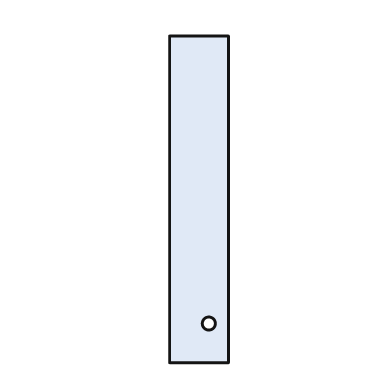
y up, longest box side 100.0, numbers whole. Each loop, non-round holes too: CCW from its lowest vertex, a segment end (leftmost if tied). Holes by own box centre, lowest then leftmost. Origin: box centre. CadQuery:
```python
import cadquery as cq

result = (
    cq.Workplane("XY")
    .moveTo(-9.0, -50.0)
    .lineTo(9.0, -50.0)
    .lineTo(9.0, 50.0)
    .lineTo(-9.0, 50.0)
    .close()
    .moveTo(3.0, -38.0)
    .circle(2.0)
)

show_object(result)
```